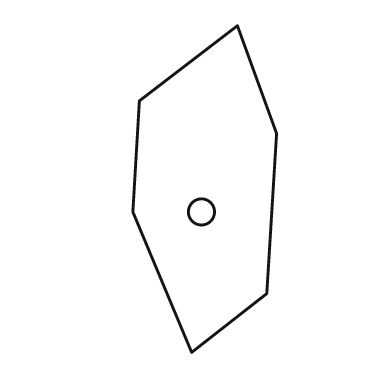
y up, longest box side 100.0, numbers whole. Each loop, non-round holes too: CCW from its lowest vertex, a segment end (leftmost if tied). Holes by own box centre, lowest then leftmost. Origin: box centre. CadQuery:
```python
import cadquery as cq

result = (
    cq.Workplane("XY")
    .moveTo(-4.0, -50.0)
    .lineTo(19.0, -32.0)
    .lineTo(22.0, 17.0)
    .lineTo(10.0, 50.0)
    .lineTo(-20.0, 27.0)
    .lineTo(-22.0, -7.0)
    .close()
    .moveTo(-1.0, -7.0)
    .circle(4.0)
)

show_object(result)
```